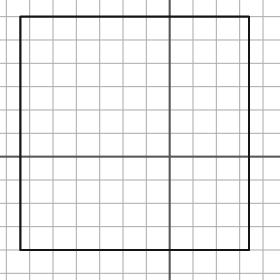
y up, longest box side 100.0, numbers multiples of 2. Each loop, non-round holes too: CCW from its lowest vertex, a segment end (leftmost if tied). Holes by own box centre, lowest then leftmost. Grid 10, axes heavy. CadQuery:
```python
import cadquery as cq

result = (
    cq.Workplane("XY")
    .moveTo(-64.0, -40.0)
    .lineTo(34.0, -40.0)
    .lineTo(34.0, 60.0)
    .lineTo(-64.0, 60.0)
    .close()
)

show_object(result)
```